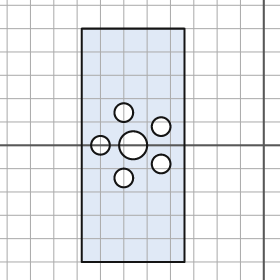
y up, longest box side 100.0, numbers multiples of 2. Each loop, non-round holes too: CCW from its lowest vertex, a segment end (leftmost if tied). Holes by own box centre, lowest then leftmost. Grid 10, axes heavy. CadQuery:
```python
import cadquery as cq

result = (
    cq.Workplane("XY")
    .moveTo(-78.0, -50.0)
    .lineTo(-34.0, -50.0)
    .lineTo(-34.0, 50.0)
    .lineTo(-78.0, 50.0)
    .close()
    .moveTo(-60.0, -14.0)
    .circle(4.0)
    .moveTo(-44.0, -8.0)
    .circle(4.0)
    .moveTo(-70.0, 0.0)
    .circle(4.0)
    .moveTo(-56.0, 0.0)
    .circle(6.0)
    .moveTo(-44.0, 8.0)
    .circle(4.0)
    .moveTo(-60.0, 14.0)
    .circle(4.0)
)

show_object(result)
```